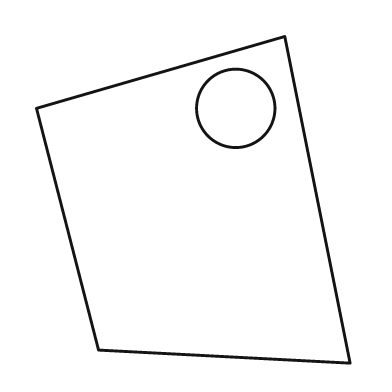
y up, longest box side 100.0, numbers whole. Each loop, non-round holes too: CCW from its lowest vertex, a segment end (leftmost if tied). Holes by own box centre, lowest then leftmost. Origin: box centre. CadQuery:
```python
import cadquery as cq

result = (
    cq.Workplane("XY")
    .moveTo(48.0, -50.0)
    .lineTo(28.0, 50.0)
    .lineTo(-48.0, 28.0)
    .lineTo(-29.0, -46.0)
    .close()
    .moveTo(13.0, 28.0)
    .circle(12.0)
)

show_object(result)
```